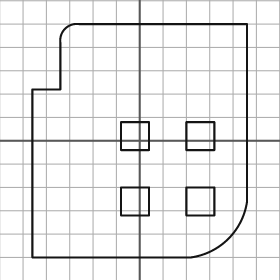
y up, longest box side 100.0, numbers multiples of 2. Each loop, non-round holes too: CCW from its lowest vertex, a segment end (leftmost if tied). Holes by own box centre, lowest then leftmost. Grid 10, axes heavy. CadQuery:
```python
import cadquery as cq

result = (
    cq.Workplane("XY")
    .moveTo(-46.0, -50.0)
    .lineTo(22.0, -50.0)
    .threePointArc((38.0, -42.0), (46.0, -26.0))
    .lineTo(46.0, 50.0)
    .lineTo(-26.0, 50.0)
    .threePointArc((-32.0, 48.0), (-34.0, 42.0))
    .lineTo(-34.0, 22.0)
    .lineTo(-46.0, 22.0)
    .close()
    .moveTo(-8.0, -32.0)
    .lineTo(4.0, -32.0)
    .lineTo(4.0, -20.0)
    .lineTo(-8.0, -20.0)
    .close()
    .moveTo(20.0, -32.0)
    .lineTo(32.0, -32.0)
    .lineTo(32.0, -20.0)
    .lineTo(20.0, -20.0)
    .close()
    .moveTo(-8.0, -4.0)
    .lineTo(4.0, -4.0)
    .lineTo(4.0, 8.0)
    .lineTo(-8.0, 8.0)
    .close()
    .moveTo(20.0, -4.0)
    .lineTo(32.0, -4.0)
    .lineTo(32.0, 8.0)
    .lineTo(20.0, 8.0)
    .close()
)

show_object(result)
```